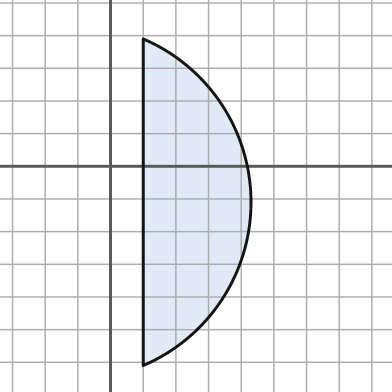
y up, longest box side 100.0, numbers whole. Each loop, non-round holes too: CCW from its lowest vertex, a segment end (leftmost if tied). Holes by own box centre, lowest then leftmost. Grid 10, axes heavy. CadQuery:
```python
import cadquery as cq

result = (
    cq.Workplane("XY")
    .moveTo(10.0, -61.0)
    .threePointArc((43.0, -11.0), (10.0, 39.0))
    .close()
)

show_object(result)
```